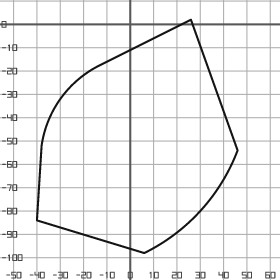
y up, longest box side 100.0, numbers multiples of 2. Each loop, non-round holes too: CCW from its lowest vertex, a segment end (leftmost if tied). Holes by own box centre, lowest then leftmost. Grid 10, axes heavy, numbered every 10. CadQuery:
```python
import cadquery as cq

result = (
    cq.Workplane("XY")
    .moveTo(6.0, -98.0)
    .threePointArc((30.0, -80.0), (46.0, -54.0))
    .lineTo(26.0, 2.0)
    .lineTo(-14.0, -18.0)
    .threePointArc((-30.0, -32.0), (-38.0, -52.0))
    .lineTo(-40.0, -84.0)
    .close()
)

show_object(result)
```